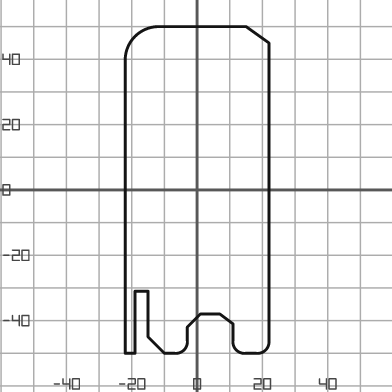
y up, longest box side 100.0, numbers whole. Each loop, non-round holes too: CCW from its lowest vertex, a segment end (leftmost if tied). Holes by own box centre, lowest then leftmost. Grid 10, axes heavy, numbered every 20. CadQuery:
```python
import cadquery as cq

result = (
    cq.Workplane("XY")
    .moveTo(-22.0, -50.0)
    .lineTo(-19.0, -50.0)
    .lineTo(-19.0, -31.0)
    .lineTo(-15.0, -31.0)
    .lineTo(-15.0, -45.0)
    .lineTo(-10.0, -50.0)
    .lineTo(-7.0, -50.0)
    .threePointArc((-4.0, -49.0), (-3.0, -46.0))
    .lineTo(-3.0, -42.0)
    .lineTo(1.0, -38.0)
    .lineTo(7.0, -38.0)
    .lineTo(11.0, -41.0)
    .lineTo(11.0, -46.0)
    .threePointArc((12.0, -49.0), (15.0, -50.0))
    .lineTo(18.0, -50.0)
    .threePointArc((21.0, -49.0), (22.0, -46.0))
    .lineTo(22.0, 45.0)
    .lineTo(15.0, 50.0)
    .lineTo(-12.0, 50.0)
    .threePointArc((-19.0, 47.0), (-22.0, 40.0))
    .close()
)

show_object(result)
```